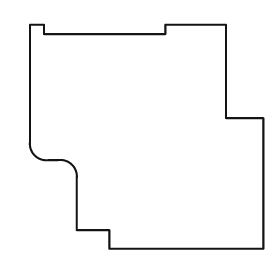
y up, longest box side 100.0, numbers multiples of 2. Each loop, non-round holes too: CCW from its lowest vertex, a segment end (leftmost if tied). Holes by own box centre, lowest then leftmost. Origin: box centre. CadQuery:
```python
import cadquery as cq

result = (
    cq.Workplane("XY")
    .moveTo(-16.0, -48.0)
    .lineTo(50.0, -48.0)
    .lineTo(50.0, 8.0)
    .lineTo(34.0, 8.0)
    .lineTo(34.0, 48.0)
    .lineTo(8.0, 48.0)
    .lineTo(8.0, 44.0)
    .lineTo(-44.0, 44.0)
    .lineTo(-44.0, 48.0)
    .lineTo(-50.0, 48.0)
    .lineTo(-50.0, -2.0)
    .threePointArc((-48.0, -8.0), (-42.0, -10.0))
    .lineTo(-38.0, -10.0)
    .threePointArc((-32.0, -12.0), (-30.0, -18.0))
    .lineTo(-30.0, -40.0)
    .lineTo(-16.0, -40.0)
    .close()
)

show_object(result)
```